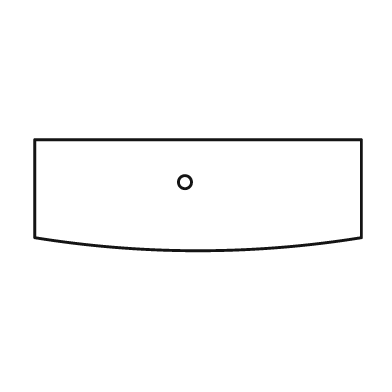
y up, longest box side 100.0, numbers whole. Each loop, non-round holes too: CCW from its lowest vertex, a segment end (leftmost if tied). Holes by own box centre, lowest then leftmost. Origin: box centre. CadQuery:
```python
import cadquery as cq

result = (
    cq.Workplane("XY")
    .moveTo(-50.0, -13.0)
    .threePointArc((0.0, -17.0), (50.0, -13.0))
    .lineTo(50.0, 17.0)
    .lineTo(-50.0, 17.0)
    .close()
    .moveTo(-4.0, 4.0)
    .circle(2.0)
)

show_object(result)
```